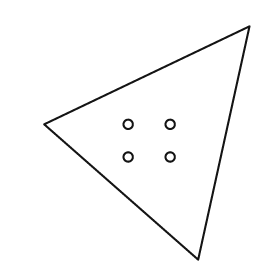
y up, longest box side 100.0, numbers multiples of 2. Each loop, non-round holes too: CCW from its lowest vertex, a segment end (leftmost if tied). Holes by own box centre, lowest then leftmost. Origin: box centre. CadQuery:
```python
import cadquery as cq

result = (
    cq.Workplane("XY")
    .moveTo(22.0, -50.0)
    .lineTo(44.0, 50.0)
    .lineTo(-44.0, 8.0)
    .close()
    .moveTo(-8.0, -6.0)
    .circle(2.0)
    .moveTo(10.0, -6.0)
    .circle(2.0)
    .moveTo(-8.0, 8.0)
    .circle(2.0)
    .moveTo(10.0, 8.0)
    .circle(2.0)
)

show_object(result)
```